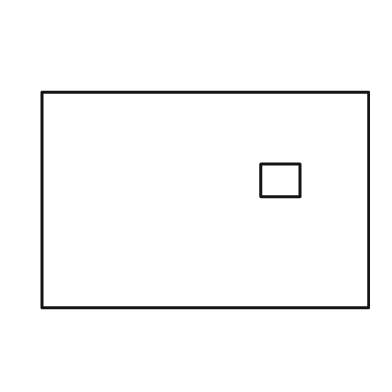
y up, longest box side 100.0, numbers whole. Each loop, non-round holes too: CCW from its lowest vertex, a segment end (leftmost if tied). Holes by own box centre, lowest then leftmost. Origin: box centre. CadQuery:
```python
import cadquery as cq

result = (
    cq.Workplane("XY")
    .moveTo(-50.0, -33.0)
    .lineTo(50.0, -33.0)
    .lineTo(50.0, 33.0)
    .lineTo(-50.0, 33.0)
    .close()
    .moveTo(17.0, 1.0)
    .lineTo(29.0, 1.0)
    .lineTo(29.0, 11.0)
    .lineTo(17.0, 11.0)
    .close()
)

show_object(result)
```